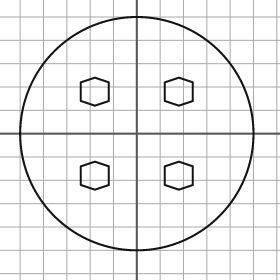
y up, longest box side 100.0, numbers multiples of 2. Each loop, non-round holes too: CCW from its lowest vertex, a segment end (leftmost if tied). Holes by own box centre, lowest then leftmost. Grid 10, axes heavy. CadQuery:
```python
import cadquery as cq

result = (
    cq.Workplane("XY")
    .moveTo(0.0, 0.0)
    .circle(50.0)
    .moveTo(-18.0, -24.0)
    .lineTo(-12.0, -22.0)
    .lineTo(-12.0, -14.0)
    .lineTo(-18.0, -12.0)
    .lineTo(-24.0, -14.0)
    .lineTo(-24.0, -22.0)
    .close()
    .moveTo(18.0, -24.0)
    .lineTo(24.0, -22.0)
    .lineTo(24.0, -14.0)
    .lineTo(18.0, -12.0)
    .lineTo(12.0, -14.0)
    .lineTo(12.0, -22.0)
    .close()
    .moveTo(-18.0, 12.0)
    .lineTo(-12.0, 14.0)
    .lineTo(-12.0, 22.0)
    .lineTo(-18.0, 24.0)
    .lineTo(-24.0, 22.0)
    .lineTo(-24.0, 14.0)
    .close()
    .moveTo(18.0, 12.0)
    .lineTo(24.0, 14.0)
    .lineTo(24.0, 22.0)
    .lineTo(18.0, 24.0)
    .lineTo(12.0, 22.0)
    .lineTo(12.0, 14.0)
    .close()
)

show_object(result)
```